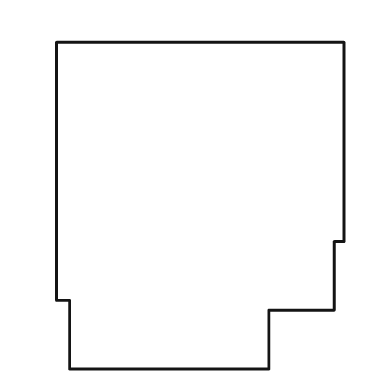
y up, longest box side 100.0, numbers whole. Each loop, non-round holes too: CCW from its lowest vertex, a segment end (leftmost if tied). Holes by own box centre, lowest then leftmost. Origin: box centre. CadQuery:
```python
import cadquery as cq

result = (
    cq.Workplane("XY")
    .moveTo(-40.0, -50.0)
    .lineTo(21.0, -50.0)
    .lineTo(21.0, -32.0)
    .lineTo(41.0, -32.0)
    .lineTo(41.0, -11.0)
    .lineTo(44.0, -11.0)
    .lineTo(44.0, 50.0)
    .lineTo(-44.0, 50.0)
    .lineTo(-44.0, -29.0)
    .lineTo(-40.0, -29.0)
    .close()
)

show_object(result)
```